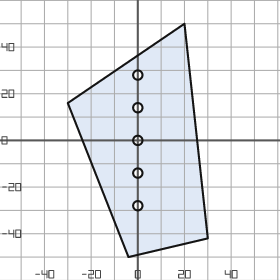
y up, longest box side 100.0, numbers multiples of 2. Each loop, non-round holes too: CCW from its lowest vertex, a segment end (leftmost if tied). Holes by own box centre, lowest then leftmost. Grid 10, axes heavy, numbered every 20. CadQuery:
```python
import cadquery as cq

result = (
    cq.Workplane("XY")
    .moveTo(-4.0, -50.0)
    .lineTo(30.0, -42.0)
    .lineTo(20.0, 50.0)
    .lineTo(-30.0, 16.0)
    .close()
    .moveTo(0.0, -28.0)
    .circle(2.0)
    .moveTo(0.0, -14.0)
    .circle(2.0)
    .moveTo(0.0, 0.0)
    .circle(2.0)
    .moveTo(0.0, 14.0)
    .circle(2.0)
    .moveTo(0.0, 28.0)
    .circle(2.0)
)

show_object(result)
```